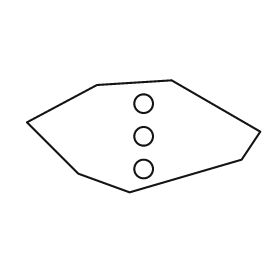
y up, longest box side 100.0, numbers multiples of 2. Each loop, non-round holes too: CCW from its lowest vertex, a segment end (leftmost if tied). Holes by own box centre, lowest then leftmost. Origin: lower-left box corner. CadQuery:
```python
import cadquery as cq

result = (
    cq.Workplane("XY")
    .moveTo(44.0, 0.0)
    .lineTo(92.0, 14.0)
    .lineTo(100.0, 26.0)
    .lineTo(62.0, 48.0)
    .lineTo(30.0, 46.0)
    .lineTo(0.0, 30.0)
    .lineTo(22.0, 8.0)
    .close()
    .moveTo(50.0, 10.0)
    .circle(4.0)
    .moveTo(50.0, 24.0)
    .circle(4.0)
    .moveTo(50.0, 38.0)
    .circle(4.0)
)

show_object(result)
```